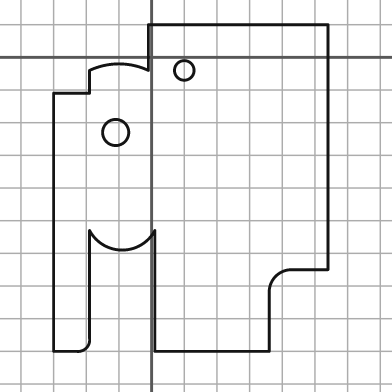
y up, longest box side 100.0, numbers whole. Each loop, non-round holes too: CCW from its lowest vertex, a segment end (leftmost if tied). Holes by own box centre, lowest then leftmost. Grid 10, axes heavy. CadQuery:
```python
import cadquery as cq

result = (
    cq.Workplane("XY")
    .moveTo(-30.0, -90.0)
    .lineTo(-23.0, -90.0)
    .threePointArc((-20.0, -89.0), (-19.0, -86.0))
    .lineTo(-19.0, -53.0)
    .threePointArc((-9.0, -59.0), (1.0, -53.0))
    .lineTo(1.0, -90.0)
    .lineTo(36.0, -90.0)
    .lineTo(36.0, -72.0)
    .threePointArc((38.0, -67.0), (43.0, -65.0))
    .lineTo(54.0, -65.0)
    .lineTo(54.0, 10.0)
    .lineTo(-1.0, 10.0)
    .lineTo(-1.0, -4.0)
    .threePointArc((-10.0, -2.0), (-19.0, -4.0))
    .lineTo(-19.0, -11.0)
    .lineTo(-30.0, -11.0)
    .close()
    .moveTo(-11.0, -23.0)
    .circle(4.0)
    .moveTo(10.0, -4.0)
    .circle(3.0)
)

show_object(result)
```